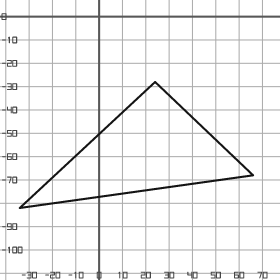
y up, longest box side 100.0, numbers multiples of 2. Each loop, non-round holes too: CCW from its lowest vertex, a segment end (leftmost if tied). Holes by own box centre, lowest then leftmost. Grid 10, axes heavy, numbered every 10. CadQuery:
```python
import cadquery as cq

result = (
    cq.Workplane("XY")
    .moveTo(-34.0, -82.0)
    .lineTo(66.0, -68.0)
    .lineTo(24.0, -28.0)
    .close()
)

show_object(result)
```